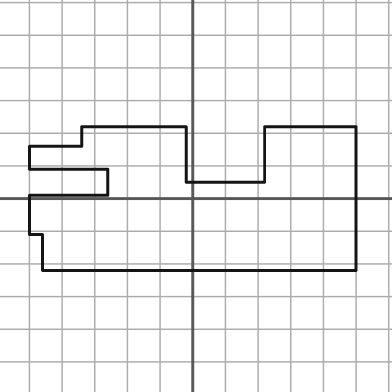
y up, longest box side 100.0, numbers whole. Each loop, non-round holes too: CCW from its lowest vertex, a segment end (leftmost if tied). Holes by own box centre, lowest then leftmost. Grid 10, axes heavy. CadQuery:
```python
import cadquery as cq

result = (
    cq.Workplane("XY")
    .moveTo(-46.0, -22.0)
    .lineTo(50.0, -22.0)
    .lineTo(50.0, 22.0)
    .lineTo(22.0, 22.0)
    .lineTo(22.0, 5.0)
    .lineTo(-2.0, 5.0)
    .lineTo(-2.0, 22.0)
    .lineTo(-34.0, 22.0)
    .lineTo(-34.0, 16.0)
    .lineTo(-50.0, 16.0)
    .lineTo(-50.0, 9.0)
    .lineTo(-26.0, 9.0)
    .lineTo(-26.0, 1.0)
    .lineTo(-50.0, 1.0)
    .lineTo(-50.0, -11.0)
    .lineTo(-46.0, -11.0)
    .close()
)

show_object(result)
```